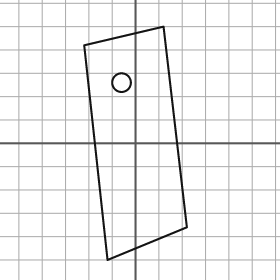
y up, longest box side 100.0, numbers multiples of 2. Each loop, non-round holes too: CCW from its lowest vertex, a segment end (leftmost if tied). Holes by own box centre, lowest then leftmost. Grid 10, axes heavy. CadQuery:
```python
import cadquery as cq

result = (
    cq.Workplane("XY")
    .moveTo(-12.0, -50.0)
    .lineTo(22.0, -36.0)
    .lineTo(12.0, 50.0)
    .lineTo(-22.0, 42.0)
    .close()
    .moveTo(-6.0, 26.0)
    .circle(4.0)
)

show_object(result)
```